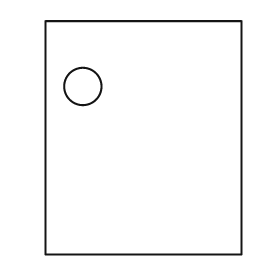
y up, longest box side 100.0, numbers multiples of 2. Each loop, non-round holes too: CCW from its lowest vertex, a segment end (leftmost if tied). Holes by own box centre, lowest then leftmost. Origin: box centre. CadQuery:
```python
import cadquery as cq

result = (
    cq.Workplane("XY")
    .moveTo(-42.0, -50.0)
    .lineTo(42.0, -50.0)
    .lineTo(42.0, 50.0)
    .lineTo(-42.0, 50.0)
    .close()
    .moveTo(-26.0, 22.0)
    .circle(8.0)
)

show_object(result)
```